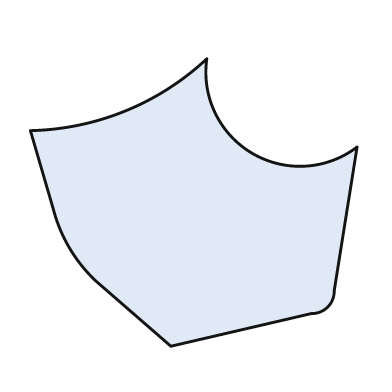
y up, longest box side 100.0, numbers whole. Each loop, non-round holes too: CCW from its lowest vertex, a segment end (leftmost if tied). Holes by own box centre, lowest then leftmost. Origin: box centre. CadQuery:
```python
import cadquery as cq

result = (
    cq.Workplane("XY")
    .moveTo(-7.0, -44.0)
    .lineTo(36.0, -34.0)
    .threePointArc((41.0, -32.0), (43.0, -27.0))
    .lineTo(50.0, 17.0)
    .threePointArc((18.0, 15.0), (4.0, 44.0))
    .threePointArc((-21.0, 28.0), (-50.0, 22.0))
    .lineTo(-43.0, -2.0)
    .threePointArc((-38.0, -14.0), (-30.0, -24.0))
    .close()
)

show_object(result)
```